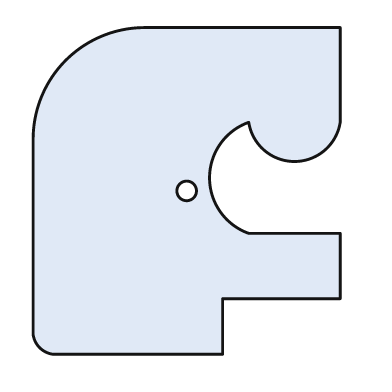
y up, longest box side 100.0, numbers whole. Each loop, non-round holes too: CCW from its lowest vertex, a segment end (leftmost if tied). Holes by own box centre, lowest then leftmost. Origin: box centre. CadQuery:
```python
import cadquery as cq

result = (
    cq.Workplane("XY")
    .moveTo(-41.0, -50.0)
    .lineTo(11.0, -50.0)
    .lineTo(11.0, -33.0)
    .lineTo(47.0, -33.0)
    .lineTo(47.0, -13.0)
    .lineTo(19.0, -13.0)
    .threePointArc((7.0, 4.0), (19.0, 21.0))
    .threePointArc((33.0, 9.0), (47.0, 21.0))
    .lineTo(47.0, 50.0)
    .lineTo(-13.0, 50.0)
    .threePointArc((-37.0, 40.0), (-47.0, 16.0))
    .lineTo(-47.0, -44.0)
    .threePointArc((-45.0, -48.0), (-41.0, -50.0))
    .close()
    .moveTo(0.0, 0.0)
    .circle(3.0)
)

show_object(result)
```